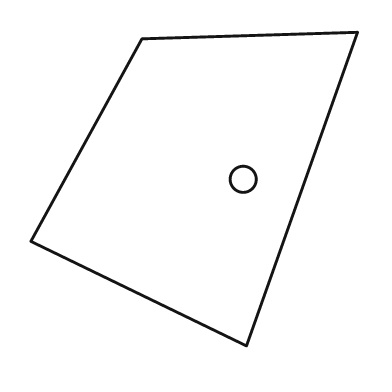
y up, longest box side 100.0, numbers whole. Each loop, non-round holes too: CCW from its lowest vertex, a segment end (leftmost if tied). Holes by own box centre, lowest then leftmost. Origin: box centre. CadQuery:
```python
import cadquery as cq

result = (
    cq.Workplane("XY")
    .moveTo(16.0, -48.0)
    .lineTo(50.0, 48.0)
    .lineTo(-16.0, 46.0)
    .lineTo(-50.0, -16.0)
    .close()
    .moveTo(15.0, 3.0)
    .circle(4.0)
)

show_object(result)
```